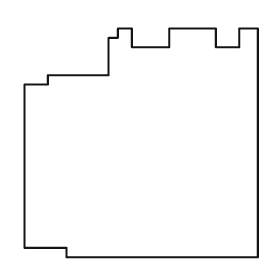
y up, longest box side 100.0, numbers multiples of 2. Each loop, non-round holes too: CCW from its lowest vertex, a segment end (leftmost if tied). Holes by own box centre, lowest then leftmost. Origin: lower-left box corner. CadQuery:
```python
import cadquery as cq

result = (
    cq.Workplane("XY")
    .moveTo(18.0, 0.0)
    .lineTo(100.0, 0.0)
    .lineTo(100.0, 98.0)
    .lineTo(92.0, 98.0)
    .lineTo(92.0, 90.0)
    .lineTo(82.0, 90.0)
    .lineTo(82.0, 98.0)
    .lineTo(62.0, 98.0)
    .lineTo(62.0, 90.0)
    .lineTo(46.0, 90.0)
    .lineTo(46.0, 98.0)
    .lineTo(40.0, 98.0)
    .lineTo(40.0, 94.0)
    .lineTo(36.0, 94.0)
    .lineTo(36.0, 78.0)
    .lineTo(10.0, 78.0)
    .lineTo(10.0, 74.0)
    .lineTo(0.0, 74.0)
    .lineTo(0.0, 4.0)
    .lineTo(18.0, 4.0)
    .close()
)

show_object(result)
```